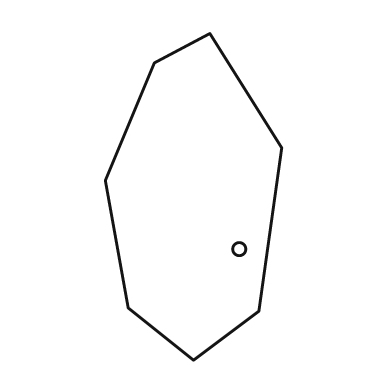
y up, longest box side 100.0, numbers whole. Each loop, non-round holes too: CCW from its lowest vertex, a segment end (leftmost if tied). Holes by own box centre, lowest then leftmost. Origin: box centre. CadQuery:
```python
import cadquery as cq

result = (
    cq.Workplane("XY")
    .moveTo(0.0, -50.0)
    .lineTo(20.0, -35.0)
    .lineTo(27.0, 15.0)
    .lineTo(5.0, 50.0)
    .lineTo(-12.0, 41.0)
    .lineTo(-27.0, 5.0)
    .lineTo(-20.0, -34.0)
    .close()
    .moveTo(14.0, -16.0)
    .circle(2.0)
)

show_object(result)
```